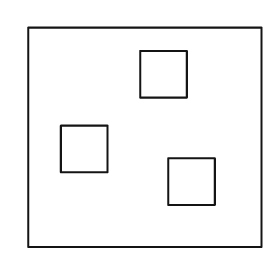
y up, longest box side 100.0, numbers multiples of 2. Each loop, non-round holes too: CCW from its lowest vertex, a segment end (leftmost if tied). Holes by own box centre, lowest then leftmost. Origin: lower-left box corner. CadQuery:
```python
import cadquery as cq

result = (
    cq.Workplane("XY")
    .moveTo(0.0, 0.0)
    .lineTo(100.0, 0.0)
    .lineTo(100.0, 94.0)
    .lineTo(0.0, 94.0)
    .close()
    .moveTo(60.0, 18.0)
    .lineTo(80.0, 18.0)
    .lineTo(80.0, 38.0)
    .lineTo(60.0, 38.0)
    .close()
    .moveTo(14.0, 32.0)
    .lineTo(34.0, 32.0)
    .lineTo(34.0, 52.0)
    .lineTo(14.0, 52.0)
    .close()
    .moveTo(48.0, 64.0)
    .lineTo(68.0, 64.0)
    .lineTo(68.0, 84.0)
    .lineTo(48.0, 84.0)
    .close()
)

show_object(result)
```